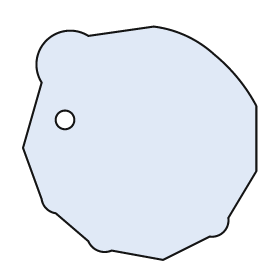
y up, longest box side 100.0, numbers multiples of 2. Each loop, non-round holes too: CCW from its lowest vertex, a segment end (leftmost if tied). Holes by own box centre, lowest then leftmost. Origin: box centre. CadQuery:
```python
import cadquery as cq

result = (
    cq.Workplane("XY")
    .moveTo(10.0, -50.0)
    .lineTo(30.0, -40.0)
    .threePointArc((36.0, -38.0), (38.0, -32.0))
    .lineTo(50.0, -12.0)
    .lineTo(50.0, 16.0)
    .threePointArc((42.0, 28.0), (32.0, 38.0))
    .threePointArc((20.0, 46.0), (6.0, 50.0))
    .lineTo(-22.0, 46.0)
    .threePointArc((-40.0, 44.0), (-42.0, 26.0))
    .lineTo(-50.0, -2.0)
    .lineTo(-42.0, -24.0)
    .threePointArc((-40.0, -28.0), (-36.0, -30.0))
    .lineTo(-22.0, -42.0)
    .threePointArc((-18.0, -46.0), (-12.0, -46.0))
    .close()
    .moveTo(-32.0, 10.0)
    .circle(4.0)
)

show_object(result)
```